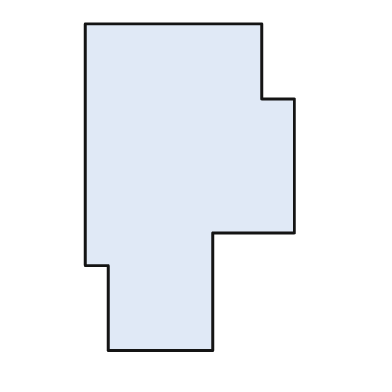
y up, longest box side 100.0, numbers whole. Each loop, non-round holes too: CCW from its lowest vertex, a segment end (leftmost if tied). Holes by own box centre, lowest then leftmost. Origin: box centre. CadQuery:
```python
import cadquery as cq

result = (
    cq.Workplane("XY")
    .moveTo(-25.0, -50.0)
    .lineTo(7.0, -50.0)
    .lineTo(7.0, -14.0)
    .lineTo(32.0, -14.0)
    .lineTo(32.0, 27.0)
    .lineTo(22.0, 27.0)
    .lineTo(22.0, 50.0)
    .lineTo(-32.0, 50.0)
    .lineTo(-32.0, -24.0)
    .lineTo(-25.0, -24.0)
    .close()
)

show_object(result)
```